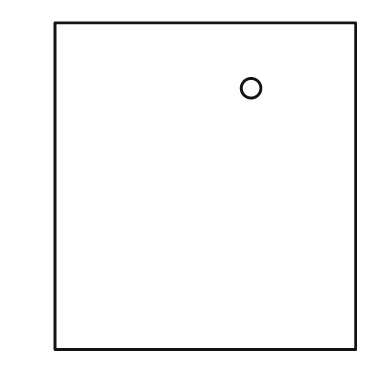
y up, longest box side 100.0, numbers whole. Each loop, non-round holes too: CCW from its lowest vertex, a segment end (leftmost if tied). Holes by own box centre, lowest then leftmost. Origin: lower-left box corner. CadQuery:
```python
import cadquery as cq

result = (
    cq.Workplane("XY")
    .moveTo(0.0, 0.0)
    .lineTo(92.0, 0.0)
    .lineTo(92.0, 100.0)
    .lineTo(0.0, 100.0)
    .close()
    .moveTo(60.0, 80.0)
    .circle(3.0)
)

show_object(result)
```